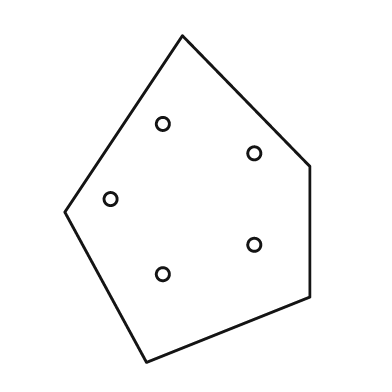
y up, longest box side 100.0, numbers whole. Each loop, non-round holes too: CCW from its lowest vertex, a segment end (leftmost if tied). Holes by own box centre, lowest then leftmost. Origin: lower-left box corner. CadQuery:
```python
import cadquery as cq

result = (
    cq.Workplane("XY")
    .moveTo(25.0, 0.0)
    .lineTo(75.0, 20.0)
    .lineTo(75.0, 60.0)
    .lineTo(36.0, 100.0)
    .lineTo(0.0, 46.0)
    .close()
    .moveTo(30.0, 27.0)
    .circle(2.0)
    .moveTo(58.0, 36.0)
    .circle(2.0)
    .moveTo(14.0, 50.0)
    .circle(2.0)
    .moveTo(58.0, 64.0)
    .circle(2.0)
    .moveTo(30.0, 73.0)
    .circle(2.0)
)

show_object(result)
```